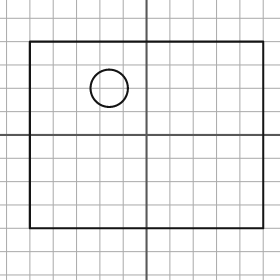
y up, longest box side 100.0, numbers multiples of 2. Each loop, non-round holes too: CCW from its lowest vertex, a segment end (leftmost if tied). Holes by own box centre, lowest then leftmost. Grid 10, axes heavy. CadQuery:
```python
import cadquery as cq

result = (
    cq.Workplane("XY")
    .moveTo(-50.0, -40.0)
    .lineTo(50.0, -40.0)
    .lineTo(50.0, 40.0)
    .lineTo(-50.0, 40.0)
    .close()
    .moveTo(-16.0, 20.0)
    .circle(8.0)
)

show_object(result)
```